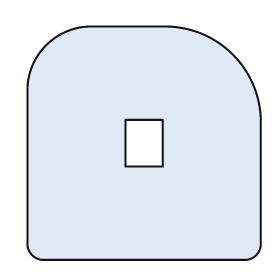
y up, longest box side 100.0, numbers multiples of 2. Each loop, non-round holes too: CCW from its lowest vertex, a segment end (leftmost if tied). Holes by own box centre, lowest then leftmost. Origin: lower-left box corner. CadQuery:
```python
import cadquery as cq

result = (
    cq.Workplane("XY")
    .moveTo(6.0, 0.0)
    .lineTo(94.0, 0.0)
    .threePointArc((98.0, 2.0), (100.0, 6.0))
    .lineTo(100.0, 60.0)
    .threePointArc((88.0, 88.0), (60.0, 100.0))
    .lineTo(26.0, 100.0)
    .threePointArc((8.0, 92.0), (0.0, 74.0))
    .lineTo(0.0, 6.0)
    .threePointArc((2.0, 2.0), (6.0, 0.0))
    .close()
    .moveTo(42.0, 40.0)
    .lineTo(58.0, 40.0)
    .lineTo(58.0, 60.0)
    .lineTo(42.0, 60.0)
    .close()
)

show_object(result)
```